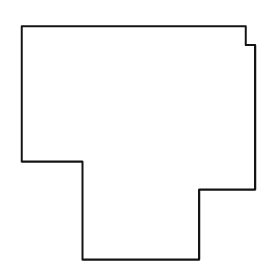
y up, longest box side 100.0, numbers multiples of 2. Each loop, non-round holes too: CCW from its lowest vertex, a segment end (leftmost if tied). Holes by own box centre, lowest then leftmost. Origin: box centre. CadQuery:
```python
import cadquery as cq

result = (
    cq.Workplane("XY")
    .moveTo(-24.0, -50.0)
    .lineTo(26.0, -50.0)
    .lineTo(26.0, -20.0)
    .lineTo(50.0, -20.0)
    .lineTo(50.0, 42.0)
    .lineTo(46.0, 42.0)
    .lineTo(46.0, 50.0)
    .lineTo(-50.0, 50.0)
    .lineTo(-50.0, -8.0)
    .lineTo(-24.0, -8.0)
    .close()
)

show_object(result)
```